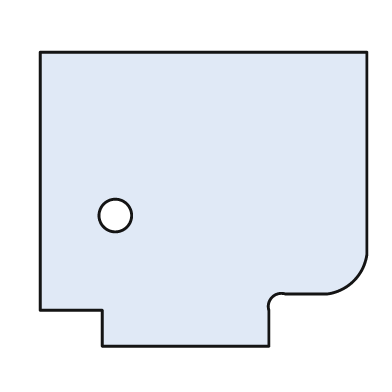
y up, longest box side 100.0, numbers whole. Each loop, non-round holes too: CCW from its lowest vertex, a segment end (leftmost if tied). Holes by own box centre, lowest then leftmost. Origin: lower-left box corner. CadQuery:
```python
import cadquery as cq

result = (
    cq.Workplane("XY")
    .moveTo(19.0, 0.0)
    .lineTo(70.0, 0.0)
    .lineTo(70.0, 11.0)
    .threePointArc((71.0, 15.0), (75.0, 16.0))
    .lineTo(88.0, 16.0)
    .threePointArc((96.0, 20.0), (100.0, 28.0))
    .lineTo(100.0, 90.0)
    .lineTo(0.0, 90.0)
    .lineTo(0.0, 11.0)
    .lineTo(19.0, 11.0)
    .close()
    .moveTo(23.0, 40.0)
    .circle(5.0)
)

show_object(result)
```